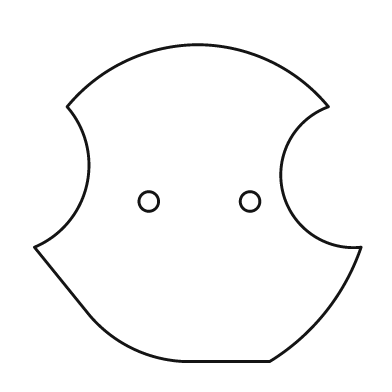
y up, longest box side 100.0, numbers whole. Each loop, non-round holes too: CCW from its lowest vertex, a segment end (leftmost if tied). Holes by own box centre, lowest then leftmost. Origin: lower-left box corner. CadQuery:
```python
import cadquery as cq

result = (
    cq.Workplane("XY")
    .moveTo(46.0, 0.0)
    .lineTo(72.0, 0.0)
    .threePointArc((89.0, 15.0), (100.0, 35.0))
    .threePointArc((76.0, 52.0), (90.0, 78.0))
    .threePointArc((72.0, 92.0), (50.0, 97.0))
    .threePointArc((28.0, 92.0), (10.0, 78.0))
    .threePointArc((16.0, 54.0), (0.0, 35.0))
    .lineTo(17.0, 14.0)
    .threePointArc((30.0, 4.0), (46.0, 0.0))
    .close()
    .moveTo(35.0, 49.0)
    .circle(3.0)
    .moveTo(66.0, 49.0)
    .circle(3.0)
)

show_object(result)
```